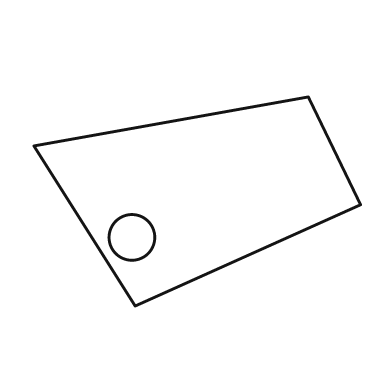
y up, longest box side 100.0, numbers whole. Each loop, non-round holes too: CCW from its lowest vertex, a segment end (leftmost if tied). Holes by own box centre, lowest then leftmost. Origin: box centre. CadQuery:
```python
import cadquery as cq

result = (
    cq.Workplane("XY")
    .moveTo(-19.0, -32.0)
    .lineTo(50.0, -1.0)
    .lineTo(34.0, 32.0)
    .lineTo(-50.0, 17.0)
    .close()
    .moveTo(-20.0, -11.0)
    .circle(7.0)
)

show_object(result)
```